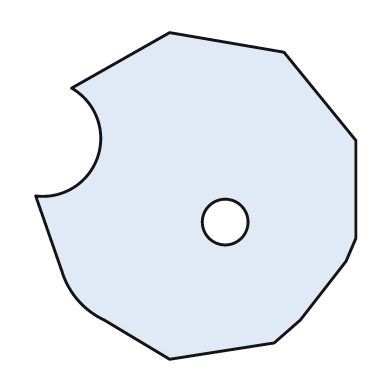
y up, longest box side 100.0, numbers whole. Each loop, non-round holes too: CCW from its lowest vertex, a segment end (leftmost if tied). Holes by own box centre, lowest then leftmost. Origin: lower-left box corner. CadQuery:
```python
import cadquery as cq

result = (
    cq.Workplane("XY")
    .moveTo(41.0, 0.0)
    .lineTo(73.0, 5.0)
    .lineTo(81.0, 12.0)
    .lineTo(95.0, 30.0)
    .lineTo(98.0, 37.0)
    .lineTo(98.0, 67.0)
    .lineTo(76.0, 94.0)
    .lineTo(41.0, 100.0)
    .lineTo(11.0, 83.0)
    .threePointArc((19.0, 62.0), (0.0, 50.0))
    .lineTo(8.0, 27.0)
    .threePointArc((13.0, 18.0), (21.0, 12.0))
    .close()
    .moveTo(58.0, 42.0)
    .circle(7.0)
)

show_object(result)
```